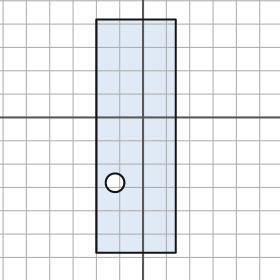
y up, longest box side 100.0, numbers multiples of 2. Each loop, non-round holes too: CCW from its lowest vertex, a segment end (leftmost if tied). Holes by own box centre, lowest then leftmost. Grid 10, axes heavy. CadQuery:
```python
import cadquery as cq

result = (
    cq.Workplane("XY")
    .moveTo(-20.0, -58.0)
    .lineTo(14.0, -58.0)
    .lineTo(14.0, 42.0)
    .lineTo(-20.0, 42.0)
    .close()
    .moveTo(-12.0, -28.0)
    .circle(4.0)
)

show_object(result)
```